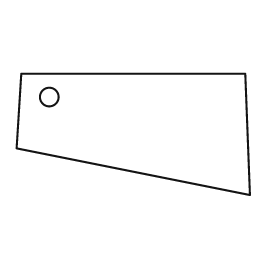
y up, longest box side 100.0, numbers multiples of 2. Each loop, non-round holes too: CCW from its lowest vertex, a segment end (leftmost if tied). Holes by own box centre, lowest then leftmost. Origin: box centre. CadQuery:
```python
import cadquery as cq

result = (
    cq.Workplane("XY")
    .moveTo(50.0, -26.0)
    .lineTo(48.0, 26.0)
    .lineTo(-48.0, 26.0)
    .lineTo(-50.0, -6.0)
    .close()
    .moveTo(-36.0, 16.0)
    .circle(4.0)
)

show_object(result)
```